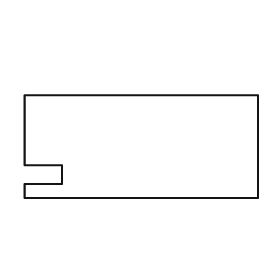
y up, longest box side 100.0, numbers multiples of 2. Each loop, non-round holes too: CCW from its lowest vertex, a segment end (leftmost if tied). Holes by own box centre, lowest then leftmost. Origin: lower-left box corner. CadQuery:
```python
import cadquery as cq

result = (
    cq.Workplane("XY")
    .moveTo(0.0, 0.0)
    .lineTo(100.0, 0.0)
    .lineTo(100.0, 44.0)
    .lineTo(0.0, 44.0)
    .lineTo(0.0, 14.0)
    .lineTo(16.0, 14.0)
    .lineTo(16.0, 6.0)
    .lineTo(0.0, 6.0)
    .close()
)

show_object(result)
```